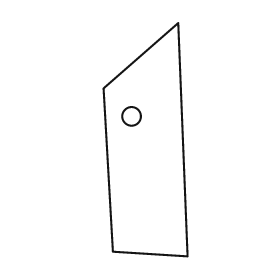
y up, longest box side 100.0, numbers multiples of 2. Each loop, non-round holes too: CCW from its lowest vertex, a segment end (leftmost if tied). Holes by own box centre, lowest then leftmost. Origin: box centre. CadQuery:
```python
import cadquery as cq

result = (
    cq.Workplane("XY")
    .moveTo(18.0, -50.0)
    .lineTo(14.0, 50.0)
    .lineTo(-18.0, 22.0)
    .lineTo(-14.0, -48.0)
    .close()
    .moveTo(-6.0, 10.0)
    .circle(4.0)
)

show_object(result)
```